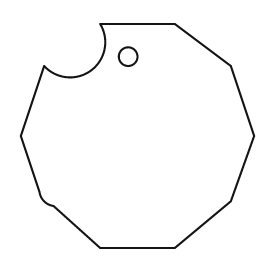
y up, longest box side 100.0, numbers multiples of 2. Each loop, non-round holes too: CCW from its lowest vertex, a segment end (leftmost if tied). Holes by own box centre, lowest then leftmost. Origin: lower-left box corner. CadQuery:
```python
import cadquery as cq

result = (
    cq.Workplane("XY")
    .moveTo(34.0, 0.0)
    .lineTo(66.0, 0.0)
    .lineTo(90.0, 20.0)
    .lineTo(100.0, 48.0)
    .lineTo(90.0, 78.0)
    .lineTo(66.0, 96.0)
    .lineTo(34.0, 96.0)
    .threePointArc((30.0, 76.0), (10.0, 78.0))
    .lineTo(0.0, 48.0)
    .lineTo(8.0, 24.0)
    .threePointArc((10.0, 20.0), (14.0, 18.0))
    .close()
    .moveTo(46.0, 82.0)
    .circle(4.0)
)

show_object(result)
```